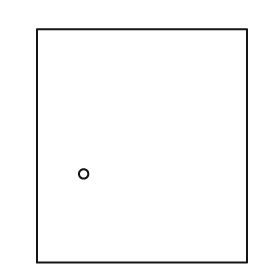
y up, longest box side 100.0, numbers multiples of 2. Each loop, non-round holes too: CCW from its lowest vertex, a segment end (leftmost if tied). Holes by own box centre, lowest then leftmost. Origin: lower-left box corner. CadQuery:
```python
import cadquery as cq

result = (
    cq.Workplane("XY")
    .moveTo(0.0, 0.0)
    .lineTo(90.0, 0.0)
    .lineTo(90.0, 100.0)
    .lineTo(0.0, 100.0)
    .close()
    .moveTo(20.0, 38.0)
    .circle(2.0)
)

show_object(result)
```